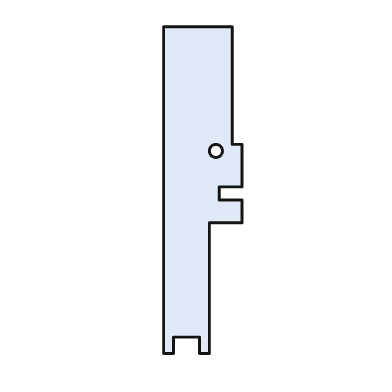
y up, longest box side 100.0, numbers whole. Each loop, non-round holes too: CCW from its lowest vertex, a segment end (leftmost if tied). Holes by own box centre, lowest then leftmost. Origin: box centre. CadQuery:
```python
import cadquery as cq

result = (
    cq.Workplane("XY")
    .moveTo(-12.0, -50.0)
    .lineTo(-9.0, -50.0)
    .lineTo(-9.0, -45.0)
    .lineTo(-1.0, -45.0)
    .lineTo(-1.0, -50.0)
    .lineTo(2.0, -50.0)
    .lineTo(2.0, -10.0)
    .lineTo(12.0, -10.0)
    .lineTo(12.0, -3.0)
    .lineTo(5.0, -3.0)
    .lineTo(5.0, 1.0)
    .lineTo(12.0, 1.0)
    .lineTo(12.0, 14.0)
    .lineTo(9.0, 14.0)
    .lineTo(9.0, 50.0)
    .lineTo(-12.0, 50.0)
    .close()
    .moveTo(4.0, 12.0)
    .circle(2.0)
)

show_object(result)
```